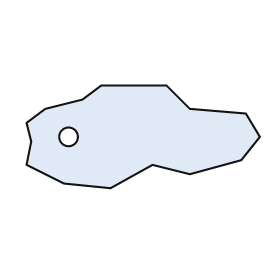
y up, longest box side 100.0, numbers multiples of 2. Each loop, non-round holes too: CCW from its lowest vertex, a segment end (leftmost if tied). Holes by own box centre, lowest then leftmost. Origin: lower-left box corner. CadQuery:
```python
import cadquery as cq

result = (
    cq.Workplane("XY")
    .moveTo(36.0, 0.0)
    .lineTo(54.0, 10.0)
    .lineTo(70.0, 6.0)
    .lineTo(92.0, 12.0)
    .lineTo(100.0, 22.0)
    .lineTo(94.0, 32.0)
    .lineTo(70.0, 34.0)
    .lineTo(60.0, 44.0)
    .lineTo(32.0, 44.0)
    .lineTo(24.0, 38.0)
    .lineTo(8.0, 34.0)
    .lineTo(0.0, 28.0)
    .lineTo(2.0, 20.0)
    .lineTo(0.0, 10.0)
    .lineTo(16.0, 2.0)
    .close()
    .moveTo(18.0, 22.0)
    .circle(4.0)
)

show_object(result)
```